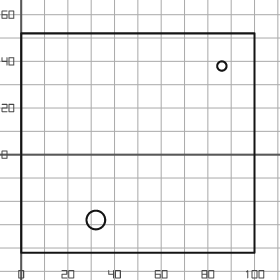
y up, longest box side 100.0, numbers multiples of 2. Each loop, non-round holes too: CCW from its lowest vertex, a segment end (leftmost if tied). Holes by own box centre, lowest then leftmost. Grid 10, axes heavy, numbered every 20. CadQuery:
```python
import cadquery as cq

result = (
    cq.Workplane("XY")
    .moveTo(0.0, -42.0)
    .lineTo(100.0, -42.0)
    .lineTo(100.0, 52.0)
    .lineTo(0.0, 52.0)
    .close()
    .moveTo(32.0, -28.0)
    .circle(4.0)
    .moveTo(86.0, 38.0)
    .circle(2.0)
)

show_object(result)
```